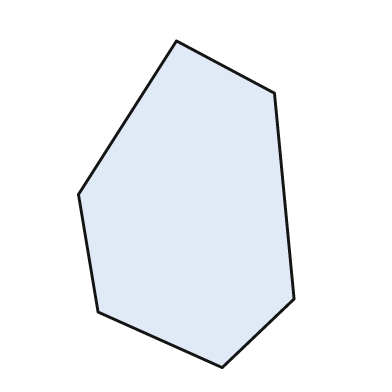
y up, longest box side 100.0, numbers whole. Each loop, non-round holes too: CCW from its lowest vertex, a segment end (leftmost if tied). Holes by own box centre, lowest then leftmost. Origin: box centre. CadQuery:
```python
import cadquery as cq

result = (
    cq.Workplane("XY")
    .moveTo(11.0, -50.0)
    .lineTo(33.0, -29.0)
    .lineTo(27.0, 34.0)
    .lineTo(-3.0, 50.0)
    .lineTo(-33.0, 3.0)
    .lineTo(-27.0, -33.0)
    .close()
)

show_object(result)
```